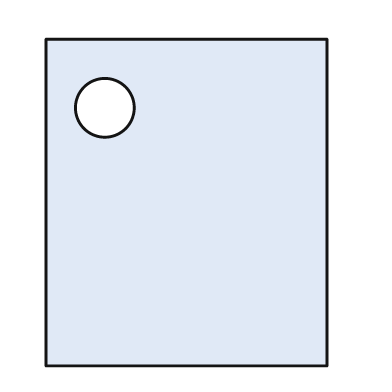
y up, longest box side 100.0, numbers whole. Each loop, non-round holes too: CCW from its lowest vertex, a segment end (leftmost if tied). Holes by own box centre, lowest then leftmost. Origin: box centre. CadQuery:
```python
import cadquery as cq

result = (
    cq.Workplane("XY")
    .moveTo(-43.0, -50.0)
    .lineTo(43.0, -50.0)
    .lineTo(43.0, 50.0)
    .lineTo(-43.0, 50.0)
    .close()
    .moveTo(-25.0, 29.0)
    .circle(9.0)
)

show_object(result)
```